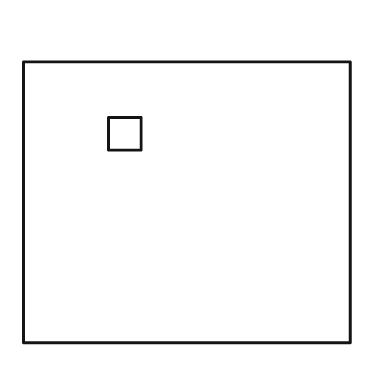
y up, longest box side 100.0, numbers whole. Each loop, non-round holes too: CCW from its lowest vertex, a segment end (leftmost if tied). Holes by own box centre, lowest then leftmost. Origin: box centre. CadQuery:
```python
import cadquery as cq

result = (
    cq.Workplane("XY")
    .moveTo(-50.0, -43.0)
    .lineTo(50.0, -43.0)
    .lineTo(50.0, 43.0)
    .lineTo(-50.0, 43.0)
    .close()
    .moveTo(-24.0, 16.0)
    .lineTo(-14.0, 16.0)
    .lineTo(-14.0, 26.0)
    .lineTo(-24.0, 26.0)
    .close()
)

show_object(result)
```